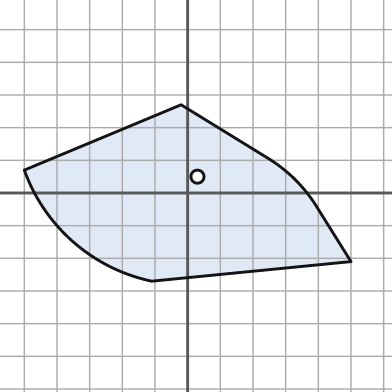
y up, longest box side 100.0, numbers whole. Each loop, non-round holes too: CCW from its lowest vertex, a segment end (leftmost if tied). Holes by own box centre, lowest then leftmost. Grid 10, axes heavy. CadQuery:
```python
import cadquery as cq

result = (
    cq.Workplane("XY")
    .moveTo(-11.0, -27.0)
    .lineTo(50.0, -21.0)
    .lineTo(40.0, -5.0)
    .threePointArc((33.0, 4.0), (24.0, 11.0))
    .lineTo(-2.0, 27.0)
    .lineTo(-50.0, 7.0)
    .threePointArc((-35.0, -15.0), (-11.0, -27.0))
    .close()
    .moveTo(3.0, 5.0)
    .circle(2.0)
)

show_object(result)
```